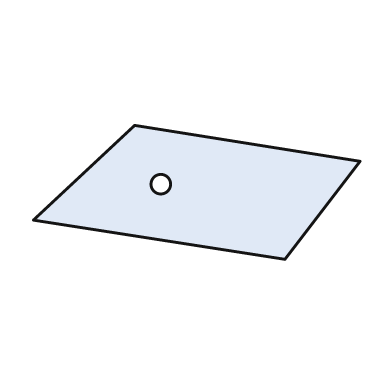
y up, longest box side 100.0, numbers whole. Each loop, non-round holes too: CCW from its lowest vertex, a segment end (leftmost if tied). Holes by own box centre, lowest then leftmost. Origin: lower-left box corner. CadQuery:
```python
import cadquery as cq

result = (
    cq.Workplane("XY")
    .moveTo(77.0, 0.0)
    .lineTo(100.0, 30.0)
    .lineTo(31.0, 41.0)
    .lineTo(0.0, 12.0)
    .close()
    .moveTo(39.0, 23.0)
    .circle(3.0)
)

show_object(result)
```